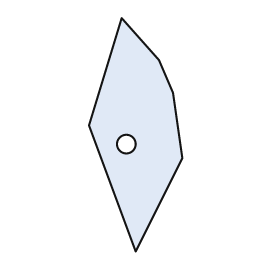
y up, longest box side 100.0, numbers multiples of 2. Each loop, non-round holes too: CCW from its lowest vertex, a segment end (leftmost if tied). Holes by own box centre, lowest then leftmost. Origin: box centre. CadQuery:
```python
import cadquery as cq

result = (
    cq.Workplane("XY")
    .moveTo(0.0, -50.0)
    .lineTo(20.0, -10.0)
    .lineTo(16.0, 18.0)
    .lineTo(10.0, 32.0)
    .lineTo(-6.0, 50.0)
    .lineTo(-20.0, 4.0)
    .close()
    .moveTo(-4.0, -4.0)
    .circle(4.0)
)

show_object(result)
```